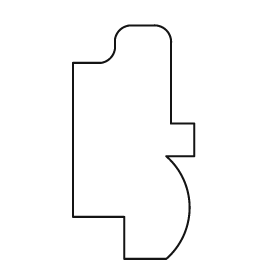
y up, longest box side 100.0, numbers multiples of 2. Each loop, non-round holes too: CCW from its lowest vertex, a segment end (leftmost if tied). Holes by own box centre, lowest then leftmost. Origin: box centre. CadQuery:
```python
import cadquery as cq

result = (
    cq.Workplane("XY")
    .moveTo(-4.0, -50.0)
    .lineTo(14.0, -50.0)
    .threePointArc((24.0, -28.0), (14.0, -6.0))
    .lineTo(26.0, -6.0)
    .lineTo(26.0, 8.0)
    .lineTo(16.0, 8.0)
    .lineTo(16.0, 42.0)
    .threePointArc((14.0, 48.0), (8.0, 50.0))
    .lineTo(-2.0, 50.0)
    .threePointArc((-6.0, 48.0), (-8.0, 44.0))
    .lineTo(-8.0, 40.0)
    .threePointArc((-10.0, 36.0), (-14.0, 34.0))
    .lineTo(-26.0, 34.0)
    .lineTo(-26.0, -32.0)
    .lineTo(-4.0, -32.0)
    .close()
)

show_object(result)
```